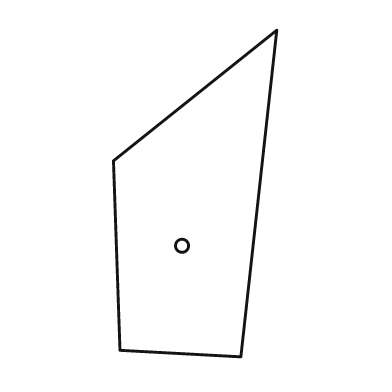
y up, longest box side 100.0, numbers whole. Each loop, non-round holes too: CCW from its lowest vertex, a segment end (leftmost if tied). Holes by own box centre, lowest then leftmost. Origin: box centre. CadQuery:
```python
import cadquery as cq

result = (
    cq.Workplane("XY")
    .moveTo(14.0, -50.0)
    .lineTo(25.0, 50.0)
    .lineTo(-25.0, 10.0)
    .lineTo(-23.0, -48.0)
    .close()
    .moveTo(-4.0, -16.0)
    .circle(2.0)
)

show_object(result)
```